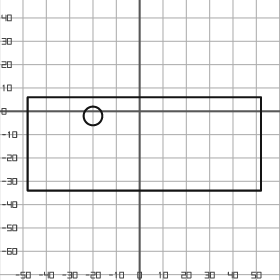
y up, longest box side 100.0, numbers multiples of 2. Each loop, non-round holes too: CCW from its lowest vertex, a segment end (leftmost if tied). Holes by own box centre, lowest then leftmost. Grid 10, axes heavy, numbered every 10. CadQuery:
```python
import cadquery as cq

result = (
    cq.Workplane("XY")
    .moveTo(-48.0, -34.0)
    .lineTo(52.0, -34.0)
    .lineTo(52.0, 6.0)
    .lineTo(-48.0, 6.0)
    .close()
    .moveTo(-20.0, -2.0)
    .circle(4.0)
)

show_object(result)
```